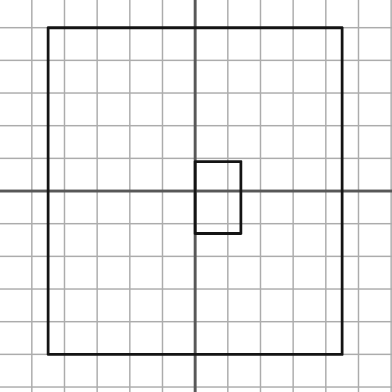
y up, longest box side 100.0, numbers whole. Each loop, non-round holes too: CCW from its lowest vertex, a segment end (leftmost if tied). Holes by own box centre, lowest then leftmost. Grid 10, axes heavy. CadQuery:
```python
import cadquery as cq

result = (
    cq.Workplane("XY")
    .moveTo(-45.0, -50.0)
    .lineTo(45.0, -50.0)
    .lineTo(45.0, 50.0)
    .lineTo(-45.0, 50.0)
    .close()
    .moveTo(0.0, -13.0)
    .lineTo(14.0, -13.0)
    .lineTo(14.0, 9.0)
    .lineTo(0.0, 9.0)
    .close()
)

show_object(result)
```